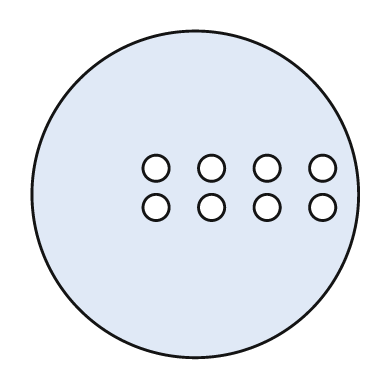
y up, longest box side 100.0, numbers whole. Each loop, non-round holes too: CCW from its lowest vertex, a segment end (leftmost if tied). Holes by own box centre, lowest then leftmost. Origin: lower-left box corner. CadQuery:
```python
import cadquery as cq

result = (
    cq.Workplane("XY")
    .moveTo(50.0, 50.0)
    .circle(50.0)
    .moveTo(38.0, 46.0)
    .circle(4.0)
    .moveTo(55.0, 46.0)
    .circle(4.0)
    .moveTo(72.0, 46.0)
    .circle(4.0)
    .moveTo(89.0, 46.0)
    .circle(4.0)
    .moveTo(38.0, 58.0)
    .circle(4.0)
    .moveTo(55.0, 58.0)
    .circle(4.0)
    .moveTo(72.0, 58.0)
    .circle(4.0)
    .moveTo(89.0, 58.0)
    .circle(4.0)
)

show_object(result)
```